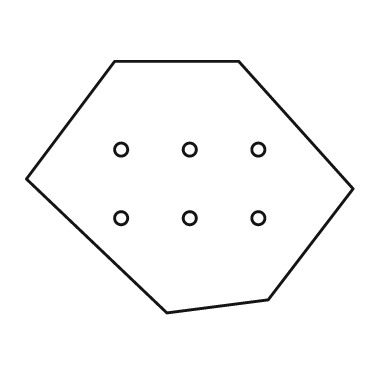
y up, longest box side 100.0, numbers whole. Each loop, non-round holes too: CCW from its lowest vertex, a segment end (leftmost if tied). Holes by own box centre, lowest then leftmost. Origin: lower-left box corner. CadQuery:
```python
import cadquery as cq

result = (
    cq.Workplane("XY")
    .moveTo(43.0, 0.0)
    .lineTo(74.0, 4.0)
    .lineTo(100.0, 38.0)
    .lineTo(65.0, 77.0)
    .lineTo(27.0, 77.0)
    .lineTo(0.0, 41.0)
    .close()
    .moveTo(29.0, 29.0)
    .circle(2.0)
    .moveTo(50.0, 29.0)
    .circle(2.0)
    .moveTo(71.0, 29.0)
    .circle(2.0)
    .moveTo(29.0, 50.0)
    .circle(2.0)
    .moveTo(50.0, 50.0)
    .circle(2.0)
    .moveTo(71.0, 50.0)
    .circle(2.0)
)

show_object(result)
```